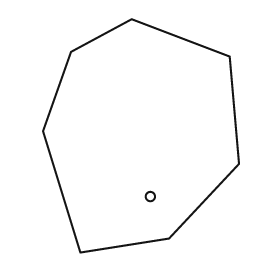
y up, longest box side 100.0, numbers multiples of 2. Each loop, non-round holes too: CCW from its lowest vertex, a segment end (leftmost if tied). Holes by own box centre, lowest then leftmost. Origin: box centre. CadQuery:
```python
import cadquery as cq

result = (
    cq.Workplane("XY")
    .moveTo(-26.0, -50.0)
    .lineTo(12.0, -44.0)
    .lineTo(42.0, -12.0)
    .lineTo(38.0, 34.0)
    .lineTo(-4.0, 50.0)
    .lineTo(-30.0, 36.0)
    .lineTo(-42.0, 2.0)
    .close()
    .moveTo(4.0, -26.0)
    .circle(2.0)
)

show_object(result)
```